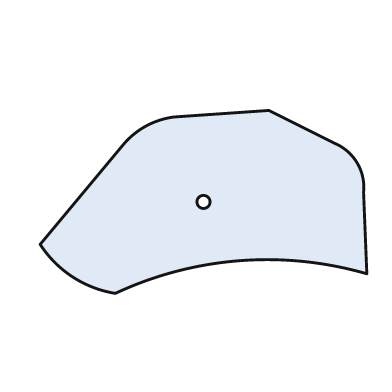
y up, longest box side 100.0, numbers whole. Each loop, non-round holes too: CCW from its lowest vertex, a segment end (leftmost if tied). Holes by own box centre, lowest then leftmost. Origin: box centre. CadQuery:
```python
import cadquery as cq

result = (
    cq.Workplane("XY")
    .moveTo(-27.0, -28.0)
    .threePointArc((11.0, -18.0), (50.0, -22.0))
    .lineTo(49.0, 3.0)
    .threePointArc((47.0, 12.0), (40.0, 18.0))
    .lineTo(20.0, 28.0)
    .lineTo(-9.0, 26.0)
    .threePointArc((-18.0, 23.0), (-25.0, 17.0))
    .lineTo(-50.0, -13.0)
    .threePointArc((-40.0, -23.0), (-27.0, -28.0))
    .close()
    .moveTo(0.0, 0.0)
    .circle(2.0)
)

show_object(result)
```